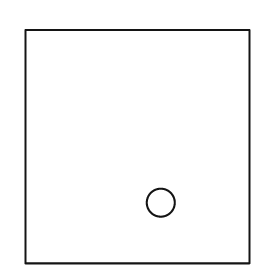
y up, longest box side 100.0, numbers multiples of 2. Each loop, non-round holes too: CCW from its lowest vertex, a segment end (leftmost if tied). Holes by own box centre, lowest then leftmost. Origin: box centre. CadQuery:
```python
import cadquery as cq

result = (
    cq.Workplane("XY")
    .moveTo(-48.0, -50.0)
    .lineTo(48.0, -50.0)
    .lineTo(48.0, 50.0)
    .lineTo(-48.0, 50.0)
    .close()
    .moveTo(10.0, -24.0)
    .circle(6.0)
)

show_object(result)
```